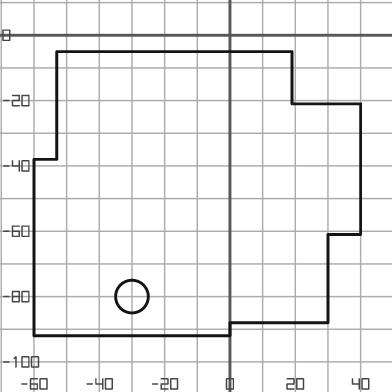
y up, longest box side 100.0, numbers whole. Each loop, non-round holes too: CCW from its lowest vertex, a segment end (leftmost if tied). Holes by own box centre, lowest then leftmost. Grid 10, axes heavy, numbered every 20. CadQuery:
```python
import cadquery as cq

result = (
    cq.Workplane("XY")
    .moveTo(-60.0, -92.0)
    .lineTo(0.0, -92.0)
    .lineTo(0.0, -88.0)
    .lineTo(30.0, -88.0)
    .lineTo(30.0, -61.0)
    .lineTo(40.0, -61.0)
    .lineTo(40.0, -21.0)
    .lineTo(19.0, -21.0)
    .lineTo(19.0, -5.0)
    .lineTo(-53.0, -5.0)
    .lineTo(-53.0, -38.0)
    .lineTo(-60.0, -38.0)
    .close()
    .moveTo(-30.0, -80.0)
    .circle(5.0)
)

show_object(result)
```